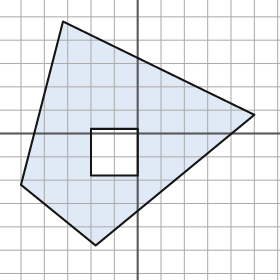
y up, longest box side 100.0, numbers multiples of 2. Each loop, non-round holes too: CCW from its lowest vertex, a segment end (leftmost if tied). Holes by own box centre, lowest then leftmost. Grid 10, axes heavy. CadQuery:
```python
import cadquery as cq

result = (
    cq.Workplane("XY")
    .moveTo(-18.0, -48.0)
    .lineTo(50.0, 8.0)
    .lineTo(-32.0, 48.0)
    .lineTo(-50.0, -22.0)
    .close()
    .moveTo(-20.0, -18.0)
    .lineTo(0.0, -18.0)
    .lineTo(0.0, 2.0)
    .lineTo(-20.0, 2.0)
    .close()
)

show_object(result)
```